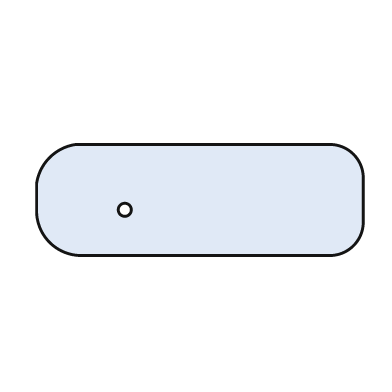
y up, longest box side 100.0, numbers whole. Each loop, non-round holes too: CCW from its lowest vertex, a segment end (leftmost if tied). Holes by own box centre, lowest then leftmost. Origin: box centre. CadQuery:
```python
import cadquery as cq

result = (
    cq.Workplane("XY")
    .moveTo(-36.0, -17.0)
    .lineTo(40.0, -17.0)
    .threePointArc((47.0, -14.0), (50.0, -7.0))
    .lineTo(50.0, 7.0)
    .threePointArc((47.0, 14.0), (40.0, 17.0))
    .lineTo(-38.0, 17.0)
    .threePointArc((-46.0, 13.0), (-50.0, 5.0))
    .lineTo(-50.0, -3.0)
    .threePointArc((-46.0, -13.0), (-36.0, -17.0))
    .close()
    .moveTo(-23.0, -3.0)
    .circle(2.0)
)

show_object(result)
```